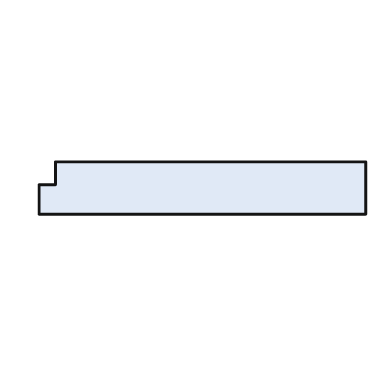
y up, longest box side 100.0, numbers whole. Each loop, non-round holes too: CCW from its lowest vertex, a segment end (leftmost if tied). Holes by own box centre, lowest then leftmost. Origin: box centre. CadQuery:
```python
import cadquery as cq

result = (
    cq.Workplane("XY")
    .moveTo(-50.0, -8.0)
    .lineTo(50.0, -8.0)
    .lineTo(50.0, 8.0)
    .lineTo(-45.0, 8.0)
    .lineTo(-45.0, 1.0)
    .lineTo(-50.0, 1.0)
    .close()
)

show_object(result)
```